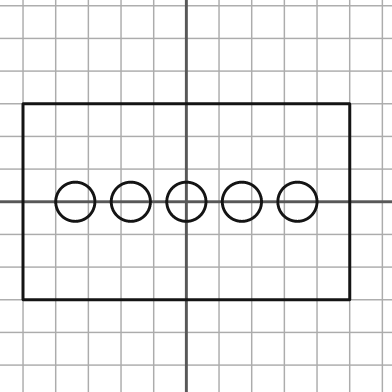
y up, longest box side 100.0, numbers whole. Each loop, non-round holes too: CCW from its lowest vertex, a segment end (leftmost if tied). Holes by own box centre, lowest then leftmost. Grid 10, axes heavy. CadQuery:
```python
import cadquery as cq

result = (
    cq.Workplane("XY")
    .moveTo(-50.0, -30.0)
    .lineTo(50.0, -30.0)
    .lineTo(50.0, 30.0)
    .lineTo(-50.0, 30.0)
    .close()
    .moveTo(-34.0, 0.0)
    .circle(6.0)
    .moveTo(-17.0, 0.0)
    .circle(6.0)
    .moveTo(0.0, 0.0)
    .circle(6.0)
    .moveTo(17.0, 0.0)
    .circle(6.0)
    .moveTo(34.0, 0.0)
    .circle(6.0)
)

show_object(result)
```